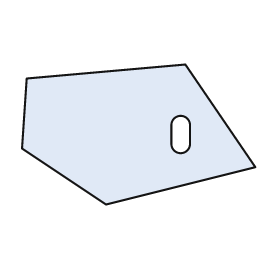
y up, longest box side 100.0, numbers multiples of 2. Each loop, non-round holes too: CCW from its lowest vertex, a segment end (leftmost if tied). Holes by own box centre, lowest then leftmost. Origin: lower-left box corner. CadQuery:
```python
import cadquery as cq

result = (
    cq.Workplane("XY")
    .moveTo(36.0, 0.0)
    .lineTo(100.0, 16.0)
    .lineTo(70.0, 60.0)
    .lineTo(2.0, 54.0)
    .lineTo(0.0, 24.0)
    .close()
    .moveTo(64.0, 26.0)
    .threePointArc((68.0, 22.0), (72.0, 26.0))
    .lineTo(72.0, 34.0)
    .threePointArc((68.0, 38.0), (64.0, 34.0))
    .close()
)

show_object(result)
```